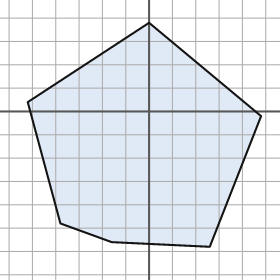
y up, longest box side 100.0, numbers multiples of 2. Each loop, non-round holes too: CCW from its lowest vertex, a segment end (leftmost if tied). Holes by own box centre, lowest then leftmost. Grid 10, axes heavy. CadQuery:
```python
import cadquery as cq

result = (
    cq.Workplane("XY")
    .moveTo(26.0, -58.0)
    .lineTo(48.0, -2.0)
    .lineTo(0.0, 38.0)
    .lineTo(-52.0, 4.0)
    .lineTo(-38.0, -48.0)
    .lineTo(-16.0, -56.0)
    .close()
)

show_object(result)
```